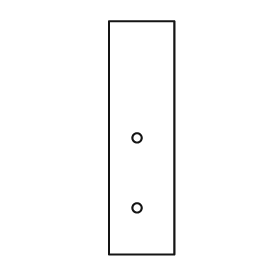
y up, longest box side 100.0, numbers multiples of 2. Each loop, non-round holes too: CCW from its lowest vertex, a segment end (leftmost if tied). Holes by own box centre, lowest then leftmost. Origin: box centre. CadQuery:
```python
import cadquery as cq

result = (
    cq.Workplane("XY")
    .moveTo(-14.0, -50.0)
    .lineTo(14.0, -50.0)
    .lineTo(14.0, 50.0)
    .lineTo(-14.0, 50.0)
    .close()
    .moveTo(-2.0, -30.0)
    .circle(2.0)
    .moveTo(-2.0, 0.0)
    .circle(2.0)
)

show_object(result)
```